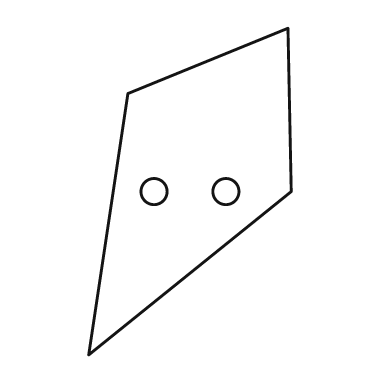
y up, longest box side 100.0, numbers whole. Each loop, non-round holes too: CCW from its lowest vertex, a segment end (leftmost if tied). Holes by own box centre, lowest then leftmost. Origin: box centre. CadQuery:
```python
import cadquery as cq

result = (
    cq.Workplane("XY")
    .moveTo(-31.0, -50.0)
    .lineTo(31.0, 0.0)
    .lineTo(30.0, 50.0)
    .lineTo(-19.0, 30.0)
    .close()
    .moveTo(-11.0, 0.0)
    .circle(4.0)
    .moveTo(11.0, 0.0)
    .circle(4.0)
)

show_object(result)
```